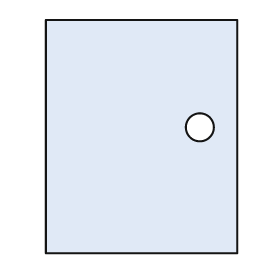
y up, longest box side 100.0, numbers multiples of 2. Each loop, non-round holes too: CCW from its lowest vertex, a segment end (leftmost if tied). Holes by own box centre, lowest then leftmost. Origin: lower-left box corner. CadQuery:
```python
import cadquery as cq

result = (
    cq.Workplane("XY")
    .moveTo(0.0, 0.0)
    .lineTo(82.0, 0.0)
    .lineTo(82.0, 100.0)
    .lineTo(0.0, 100.0)
    .close()
    .moveTo(66.0, 54.0)
    .circle(6.0)
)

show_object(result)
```